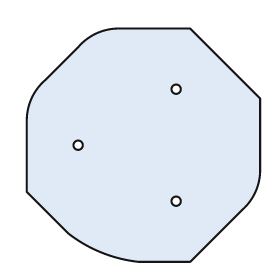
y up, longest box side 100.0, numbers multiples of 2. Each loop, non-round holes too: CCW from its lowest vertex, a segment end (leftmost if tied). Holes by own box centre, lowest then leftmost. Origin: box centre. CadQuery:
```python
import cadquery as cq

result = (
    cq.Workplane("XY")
    .moveTo(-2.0, -50.0)
    .lineTo(20.0, -50.0)
    .lineTo(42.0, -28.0)
    .threePointArc((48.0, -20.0), (50.0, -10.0))
    .lineTo(50.0, 20.0)
    .lineTo(20.0, 50.0)
    .lineTo(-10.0, 50.0)
    .threePointArc((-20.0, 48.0), (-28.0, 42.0))
    .lineTo(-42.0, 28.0)
    .threePointArc((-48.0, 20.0), (-50.0, 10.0))
    .lineTo(-50.0, -20.0)
    .lineTo(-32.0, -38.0)
    .threePointArc((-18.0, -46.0), (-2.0, -50.0))
    .close()
    .moveTo(14.0, -24.0)
    .circle(2.0)
    .moveTo(-28.0, 0.0)
    .circle(2.0)
    .moveTo(14.0, 24.0)
    .circle(2.0)
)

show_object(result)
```